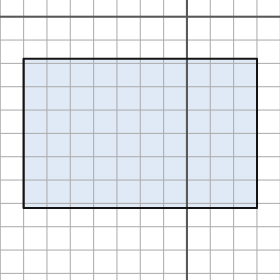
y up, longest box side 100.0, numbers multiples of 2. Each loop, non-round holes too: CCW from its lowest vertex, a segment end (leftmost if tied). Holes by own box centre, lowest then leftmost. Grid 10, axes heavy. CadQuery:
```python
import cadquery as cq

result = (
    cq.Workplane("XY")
    .moveTo(-70.0, -82.0)
    .lineTo(30.0, -82.0)
    .lineTo(30.0, -18.0)
    .lineTo(-70.0, -18.0)
    .close()
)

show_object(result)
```